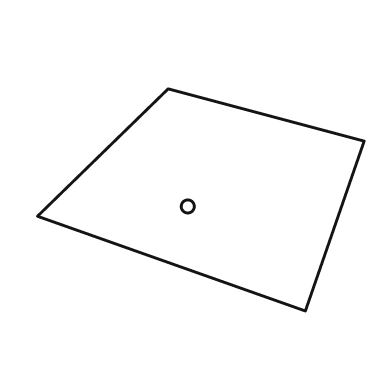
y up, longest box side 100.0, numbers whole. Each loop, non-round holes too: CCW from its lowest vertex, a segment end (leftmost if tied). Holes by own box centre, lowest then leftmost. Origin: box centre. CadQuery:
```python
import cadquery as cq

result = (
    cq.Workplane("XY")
    .moveTo(32.0, -34.0)
    .lineTo(50.0, 18.0)
    .lineTo(-10.0, 34.0)
    .lineTo(-50.0, -5.0)
    .close()
    .moveTo(-4.0, -2.0)
    .circle(2.0)
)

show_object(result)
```